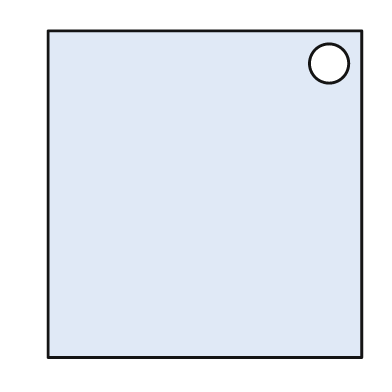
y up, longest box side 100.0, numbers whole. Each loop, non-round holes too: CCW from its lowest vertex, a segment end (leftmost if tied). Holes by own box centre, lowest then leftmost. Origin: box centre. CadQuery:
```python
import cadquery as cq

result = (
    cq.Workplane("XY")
    .moveTo(-48.0, -50.0)
    .lineTo(48.0, -50.0)
    .lineTo(48.0, 50.0)
    .lineTo(-48.0, 50.0)
    .close()
    .moveTo(38.0, 40.0)
    .circle(6.0)
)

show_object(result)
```